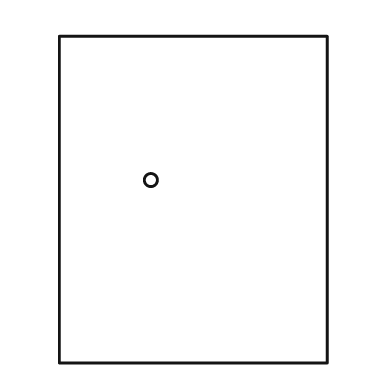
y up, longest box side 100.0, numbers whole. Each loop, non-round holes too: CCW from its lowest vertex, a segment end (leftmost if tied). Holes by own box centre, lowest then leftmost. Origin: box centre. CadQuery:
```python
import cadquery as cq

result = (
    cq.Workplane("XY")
    .moveTo(-41.0, -50.0)
    .lineTo(41.0, -50.0)
    .lineTo(41.0, 50.0)
    .lineTo(-41.0, 50.0)
    .close()
    .moveTo(-13.0, 6.0)
    .circle(2.0)
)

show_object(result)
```